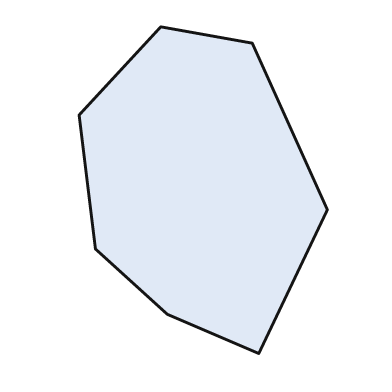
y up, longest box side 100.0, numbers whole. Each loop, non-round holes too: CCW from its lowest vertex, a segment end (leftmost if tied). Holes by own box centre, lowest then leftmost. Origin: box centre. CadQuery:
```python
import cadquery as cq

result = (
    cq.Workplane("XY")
    .moveTo(17.0, -50.0)
    .lineTo(38.0, -6.0)
    .lineTo(15.0, 45.0)
    .lineTo(-13.0, 50.0)
    .lineTo(-38.0, 23.0)
    .lineTo(-33.0, -18.0)
    .lineTo(-11.0, -38.0)
    .close()
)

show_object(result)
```